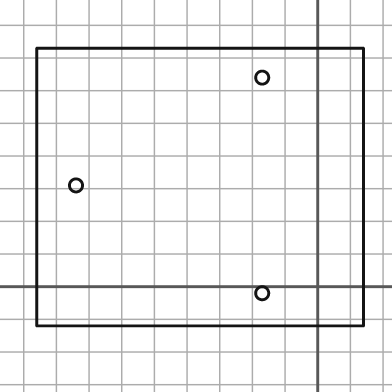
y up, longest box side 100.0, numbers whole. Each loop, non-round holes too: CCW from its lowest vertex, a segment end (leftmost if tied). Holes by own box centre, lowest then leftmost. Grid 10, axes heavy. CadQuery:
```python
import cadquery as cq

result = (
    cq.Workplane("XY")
    .moveTo(-86.0, -12.0)
    .lineTo(14.0, -12.0)
    .lineTo(14.0, 73.0)
    .lineTo(-86.0, 73.0)
    .close()
    .moveTo(-17.0, -2.0)
    .circle(2.0)
    .moveTo(-74.0, 31.0)
    .circle(2.0)
    .moveTo(-17.0, 64.0)
    .circle(2.0)
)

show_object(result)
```